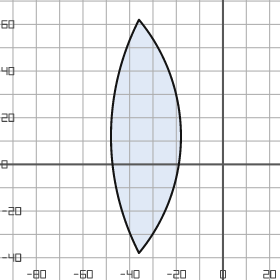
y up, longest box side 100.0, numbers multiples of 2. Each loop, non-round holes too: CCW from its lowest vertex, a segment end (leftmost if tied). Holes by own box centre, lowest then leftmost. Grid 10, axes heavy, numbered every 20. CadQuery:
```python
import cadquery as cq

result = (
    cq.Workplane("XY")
    .moveTo(-36.0, -38.0)
    .threePointArc((-18.0, 12.0), (-36.0, 62.0))
    .threePointArc((-48.0, 12.0), (-36.0, -38.0))
    .close()
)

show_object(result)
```